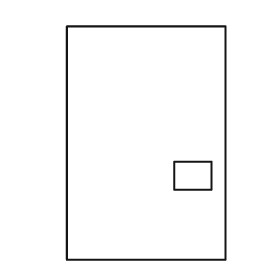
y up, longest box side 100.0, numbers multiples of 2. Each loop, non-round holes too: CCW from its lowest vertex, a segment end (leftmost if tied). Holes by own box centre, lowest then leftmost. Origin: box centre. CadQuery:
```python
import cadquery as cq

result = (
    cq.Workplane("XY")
    .moveTo(-34.0, -50.0)
    .lineTo(34.0, -50.0)
    .lineTo(34.0, 50.0)
    .lineTo(-34.0, 50.0)
    .close()
    .moveTo(12.0, -20.0)
    .lineTo(28.0, -20.0)
    .lineTo(28.0, -8.0)
    .lineTo(12.0, -8.0)
    .close()
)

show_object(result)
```